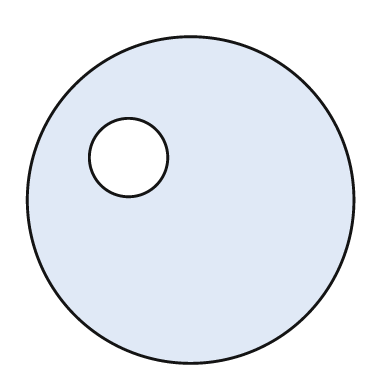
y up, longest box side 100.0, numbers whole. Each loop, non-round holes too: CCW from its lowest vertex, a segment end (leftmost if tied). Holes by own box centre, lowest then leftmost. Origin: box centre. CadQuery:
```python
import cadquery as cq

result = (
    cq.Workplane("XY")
    .moveTo(0.0, 0.0)
    .circle(50.0)
    .moveTo(-19.0, 13.0)
    .circle(12.0)
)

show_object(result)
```